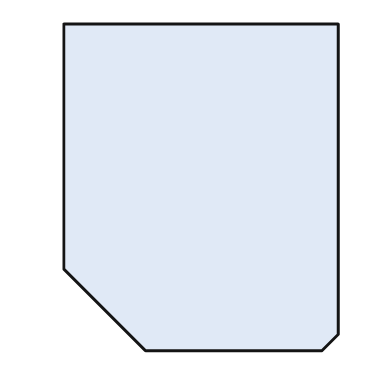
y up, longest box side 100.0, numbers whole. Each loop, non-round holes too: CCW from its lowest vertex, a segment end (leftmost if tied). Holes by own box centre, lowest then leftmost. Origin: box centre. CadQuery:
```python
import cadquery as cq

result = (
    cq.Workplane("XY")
    .moveTo(-17.0, -50.0)
    .lineTo(37.0, -50.0)
    .lineTo(42.0, -45.0)
    .lineTo(42.0, 50.0)
    .lineTo(-42.0, 50.0)
    .lineTo(-42.0, -25.0)
    .close()
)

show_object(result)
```